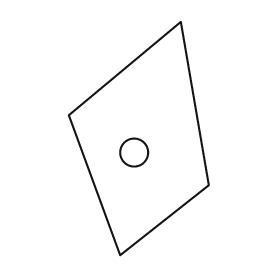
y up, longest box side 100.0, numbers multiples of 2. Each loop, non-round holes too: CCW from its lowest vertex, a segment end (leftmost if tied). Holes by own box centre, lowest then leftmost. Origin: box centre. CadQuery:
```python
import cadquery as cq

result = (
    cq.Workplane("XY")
    .moveTo(-8.0, -50.0)
    .lineTo(30.0, -20.0)
    .lineTo(18.0, 50.0)
    .lineTo(-30.0, 10.0)
    .close()
    .moveTo(-2.0, -6.0)
    .circle(6.0)
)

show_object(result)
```